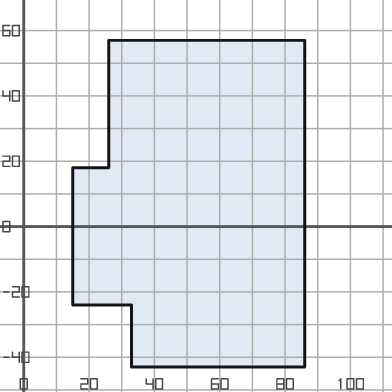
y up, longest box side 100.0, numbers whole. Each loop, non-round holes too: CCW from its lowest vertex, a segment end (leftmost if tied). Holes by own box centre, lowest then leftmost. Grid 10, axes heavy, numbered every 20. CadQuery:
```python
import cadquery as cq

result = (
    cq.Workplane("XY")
    .moveTo(33.0, -43.0)
    .lineTo(86.0, -43.0)
    .lineTo(86.0, 57.0)
    .lineTo(26.0, 57.0)
    .lineTo(26.0, 18.0)
    .lineTo(15.0, 18.0)
    .lineTo(15.0, -24.0)
    .lineTo(33.0, -24.0)
    .close()
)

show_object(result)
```